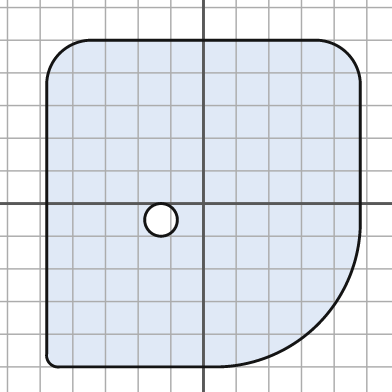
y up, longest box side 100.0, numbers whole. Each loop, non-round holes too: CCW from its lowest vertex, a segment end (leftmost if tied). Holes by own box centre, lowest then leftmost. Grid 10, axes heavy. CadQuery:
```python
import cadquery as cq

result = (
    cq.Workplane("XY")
    .moveTo(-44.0, -50.0)
    .lineTo(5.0, -50.0)
    .threePointArc((35.0, -37.0), (48.0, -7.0))
    .lineTo(48.0, 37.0)
    .threePointArc((44.0, 46.0), (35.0, 50.0))
    .lineTo(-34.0, 50.0)
    .threePointArc((-44.0, 46.0), (-48.0, 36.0))
    .lineTo(-48.0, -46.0)
    .threePointArc((-47.0, -49.0), (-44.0, -50.0))
    .close()
    .moveTo(-13.0, -5.0)
    .circle(5.0)
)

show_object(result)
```